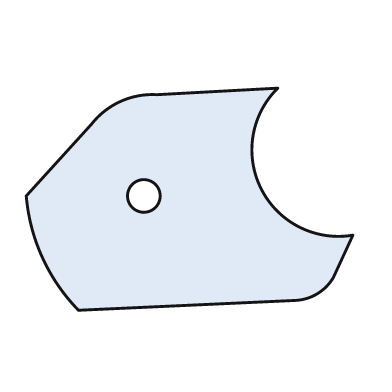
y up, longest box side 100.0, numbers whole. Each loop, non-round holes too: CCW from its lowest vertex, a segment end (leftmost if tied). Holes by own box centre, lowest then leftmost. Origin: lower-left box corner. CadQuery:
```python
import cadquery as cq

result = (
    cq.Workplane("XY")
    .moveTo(16.0, 0.0)
    .lineTo(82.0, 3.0)
    .threePointArc((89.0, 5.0), (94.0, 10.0))
    .lineTo(100.0, 23.0)
    .threePointArc((72.0, 37.0), (77.0, 68.0))
    .lineTo(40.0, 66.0)
    .threePointArc((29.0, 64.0), (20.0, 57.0))
    .lineTo(0.0, 35.0)
    .threePointArc((5.0, 16.0), (16.0, 0.0))
    .close()
    .moveTo(36.0, 35.0)
    .circle(5.0)
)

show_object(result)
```